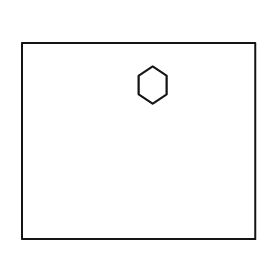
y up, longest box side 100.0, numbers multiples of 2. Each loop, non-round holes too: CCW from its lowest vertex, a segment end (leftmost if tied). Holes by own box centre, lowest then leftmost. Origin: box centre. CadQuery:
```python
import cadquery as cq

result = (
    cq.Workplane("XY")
    .moveTo(-50.0, -42.0)
    .lineTo(50.0, -42.0)
    .lineTo(50.0, 42.0)
    .lineTo(-50.0, 42.0)
    .close()
    .moveTo(6.0, 16.0)
    .lineTo(12.0, 20.0)
    .lineTo(12.0, 28.0)
    .lineTo(6.0, 32.0)
    .lineTo(0.0, 28.0)
    .lineTo(0.0, 20.0)
    .close()
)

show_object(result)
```